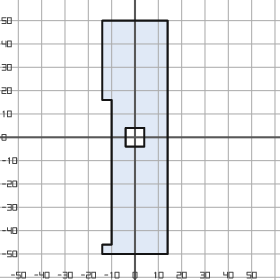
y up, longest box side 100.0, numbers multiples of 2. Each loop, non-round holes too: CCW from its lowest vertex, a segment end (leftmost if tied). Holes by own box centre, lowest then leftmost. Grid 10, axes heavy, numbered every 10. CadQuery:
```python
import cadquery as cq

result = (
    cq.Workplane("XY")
    .moveTo(-14.0, -50.0)
    .lineTo(14.0, -50.0)
    .lineTo(14.0, 50.0)
    .lineTo(-14.0, 50.0)
    .lineTo(-14.0, 16.0)
    .lineTo(-10.0, 16.0)
    .lineTo(-10.0, -46.0)
    .lineTo(-14.0, -46.0)
    .close()
    .moveTo(-4.0, -4.0)
    .lineTo(4.0, -4.0)
    .lineTo(4.0, 4.0)
    .lineTo(-4.0, 4.0)
    .close()
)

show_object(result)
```